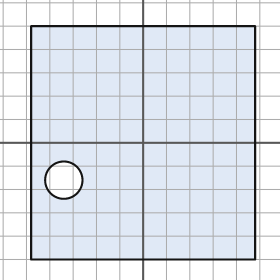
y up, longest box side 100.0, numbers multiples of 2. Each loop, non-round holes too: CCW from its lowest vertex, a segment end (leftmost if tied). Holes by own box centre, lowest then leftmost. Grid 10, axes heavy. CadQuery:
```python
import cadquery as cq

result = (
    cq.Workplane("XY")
    .moveTo(-48.0, -50.0)
    .lineTo(48.0, -50.0)
    .lineTo(48.0, 50.0)
    .lineTo(-48.0, 50.0)
    .close()
    .moveTo(-34.0, -16.0)
    .circle(8.0)
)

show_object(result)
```